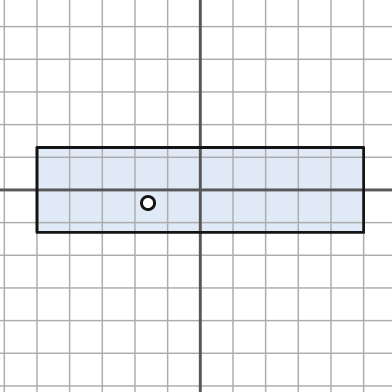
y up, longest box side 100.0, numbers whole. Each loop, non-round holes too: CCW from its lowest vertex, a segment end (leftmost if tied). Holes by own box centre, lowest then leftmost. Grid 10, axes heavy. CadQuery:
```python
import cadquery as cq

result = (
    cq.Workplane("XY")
    .moveTo(-50.0, -13.0)
    .lineTo(50.0, -13.0)
    .lineTo(50.0, 13.0)
    .lineTo(-50.0, 13.0)
    .close()
    .moveTo(-16.0, -4.0)
    .circle(2.0)
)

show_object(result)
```